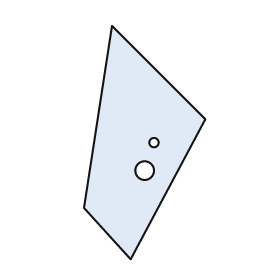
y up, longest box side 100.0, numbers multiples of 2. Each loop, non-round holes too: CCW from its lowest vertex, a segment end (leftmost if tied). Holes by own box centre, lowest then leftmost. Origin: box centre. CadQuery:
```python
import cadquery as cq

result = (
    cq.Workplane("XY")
    .moveTo(-6.0, -50.0)
    .lineTo(26.0, 10.0)
    .lineTo(-14.0, 50.0)
    .lineTo(-26.0, -28.0)
    .close()
    .moveTo(0.0, -12.0)
    .circle(4.0)
    .moveTo(4.0, 0.0)
    .circle(2.0)
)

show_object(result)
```